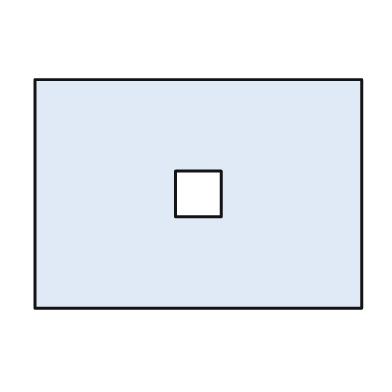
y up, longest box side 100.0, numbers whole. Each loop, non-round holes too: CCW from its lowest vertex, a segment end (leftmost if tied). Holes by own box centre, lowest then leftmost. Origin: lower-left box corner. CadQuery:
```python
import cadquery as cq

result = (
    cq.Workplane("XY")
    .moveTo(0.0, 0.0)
    .lineTo(100.0, 0.0)
    .lineTo(100.0, 70.0)
    .lineTo(0.0, 70.0)
    .close()
    .moveTo(43.0, 28.0)
    .lineTo(57.0, 28.0)
    .lineTo(57.0, 42.0)
    .lineTo(43.0, 42.0)
    .close()
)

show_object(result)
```